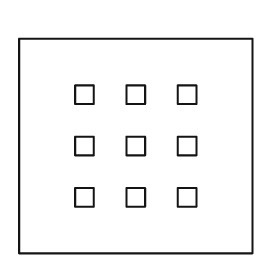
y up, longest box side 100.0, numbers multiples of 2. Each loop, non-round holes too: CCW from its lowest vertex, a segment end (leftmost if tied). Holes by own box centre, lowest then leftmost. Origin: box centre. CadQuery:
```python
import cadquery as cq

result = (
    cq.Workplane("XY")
    .moveTo(-50.0, -46.0)
    .lineTo(50.0, -46.0)
    .lineTo(50.0, 46.0)
    .lineTo(-50.0, 46.0)
    .close()
    .moveTo(-26.0, -26.0)
    .lineTo(-18.0, -26.0)
    .lineTo(-18.0, -18.0)
    .lineTo(-26.0, -18.0)
    .close()
    .moveTo(-4.0, -26.0)
    .lineTo(4.0, -26.0)
    .lineTo(4.0, -18.0)
    .lineTo(-4.0, -18.0)
    .close()
    .moveTo(18.0, -26.0)
    .lineTo(26.0, -26.0)
    .lineTo(26.0, -18.0)
    .lineTo(18.0, -18.0)
    .close()
    .moveTo(-26.0, -4.0)
    .lineTo(-18.0, -4.0)
    .lineTo(-18.0, 4.0)
    .lineTo(-26.0, 4.0)
    .close()
    .moveTo(-4.0, -4.0)
    .lineTo(4.0, -4.0)
    .lineTo(4.0, 4.0)
    .lineTo(-4.0, 4.0)
    .close()
    .moveTo(18.0, -4.0)
    .lineTo(26.0, -4.0)
    .lineTo(26.0, 4.0)
    .lineTo(18.0, 4.0)
    .close()
    .moveTo(-26.0, 18.0)
    .lineTo(-18.0, 18.0)
    .lineTo(-18.0, 26.0)
    .lineTo(-26.0, 26.0)
    .close()
    .moveTo(-4.0, 18.0)
    .lineTo(4.0, 18.0)
    .lineTo(4.0, 26.0)
    .lineTo(-4.0, 26.0)
    .close()
    .moveTo(18.0, 18.0)
    .lineTo(26.0, 18.0)
    .lineTo(26.0, 26.0)
    .lineTo(18.0, 26.0)
    .close()
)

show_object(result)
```